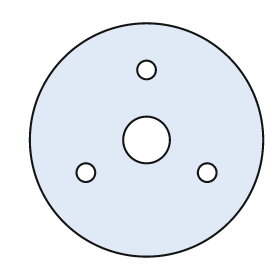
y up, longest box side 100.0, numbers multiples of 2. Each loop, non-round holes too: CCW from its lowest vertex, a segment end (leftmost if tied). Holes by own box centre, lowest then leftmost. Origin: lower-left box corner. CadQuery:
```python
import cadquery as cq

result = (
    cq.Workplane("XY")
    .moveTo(50.0, 50.0)
    .circle(50.0)
    .moveTo(24.0, 36.0)
    .circle(4.0)
    .moveTo(76.0, 36.0)
    .circle(4.0)
    .moveTo(50.0, 50.0)
    .circle(10.0)
    .moveTo(50.0, 80.0)
    .circle(4.0)
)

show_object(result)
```